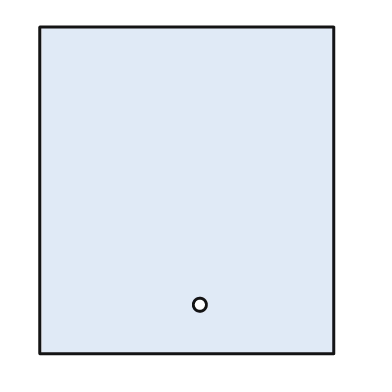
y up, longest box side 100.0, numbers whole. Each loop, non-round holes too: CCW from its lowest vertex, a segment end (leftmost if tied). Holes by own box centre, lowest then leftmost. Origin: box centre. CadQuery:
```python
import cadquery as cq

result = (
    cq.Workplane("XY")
    .moveTo(-45.0, -50.0)
    .lineTo(45.0, -50.0)
    .lineTo(45.0, 50.0)
    .lineTo(-45.0, 50.0)
    .close()
    .moveTo(4.0, -35.0)
    .circle(2.0)
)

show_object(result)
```